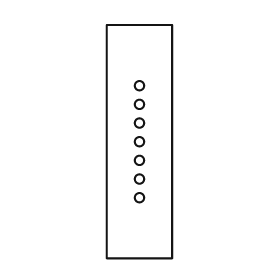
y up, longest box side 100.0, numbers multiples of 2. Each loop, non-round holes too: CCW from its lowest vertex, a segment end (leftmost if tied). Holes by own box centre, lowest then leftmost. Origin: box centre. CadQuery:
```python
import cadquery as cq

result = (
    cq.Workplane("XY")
    .moveTo(-14.0, -50.0)
    .lineTo(14.0, -50.0)
    .lineTo(14.0, 50.0)
    .lineTo(-14.0, 50.0)
    .close()
    .moveTo(0.0, -24.0)
    .circle(2.0)
    .moveTo(0.0, -16.0)
    .circle(2.0)
    .moveTo(0.0, -8.0)
    .circle(2.0)
    .moveTo(0.0, 0.0)
    .circle(2.0)
    .moveTo(0.0, 8.0)
    .circle(2.0)
    .moveTo(0.0, 16.0)
    .circle(2.0)
    .moveTo(0.0, 24.0)
    .circle(2.0)
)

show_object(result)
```